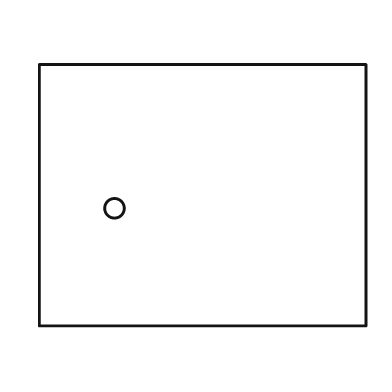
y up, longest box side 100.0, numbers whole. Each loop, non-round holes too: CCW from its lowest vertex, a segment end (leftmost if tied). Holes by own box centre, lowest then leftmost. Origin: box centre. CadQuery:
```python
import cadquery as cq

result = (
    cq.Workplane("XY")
    .moveTo(-50.0, -40.0)
    .lineTo(50.0, -40.0)
    .lineTo(50.0, 40.0)
    .lineTo(-50.0, 40.0)
    .close()
    .moveTo(-27.0, -4.0)
    .circle(3.0)
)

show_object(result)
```